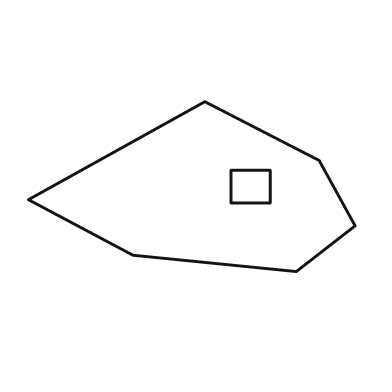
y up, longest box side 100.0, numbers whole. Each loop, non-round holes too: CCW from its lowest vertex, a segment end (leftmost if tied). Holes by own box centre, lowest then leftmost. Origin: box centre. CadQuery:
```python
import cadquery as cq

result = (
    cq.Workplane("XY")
    .moveTo(32.0, -26.0)
    .lineTo(50.0, -12.0)
    .lineTo(39.0, 8.0)
    .lineTo(4.0, 26.0)
    .lineTo(-50.0, -4.0)
    .lineTo(-18.0, -21.0)
    .close()
    .moveTo(12.0, -5.0)
    .lineTo(24.0, -5.0)
    .lineTo(24.0, 5.0)
    .lineTo(12.0, 5.0)
    .close()
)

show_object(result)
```